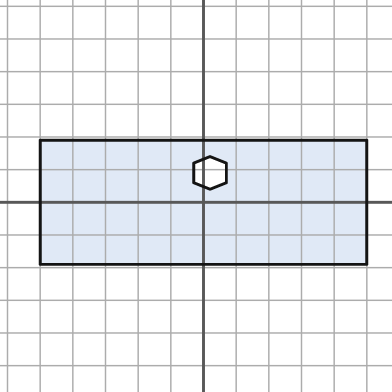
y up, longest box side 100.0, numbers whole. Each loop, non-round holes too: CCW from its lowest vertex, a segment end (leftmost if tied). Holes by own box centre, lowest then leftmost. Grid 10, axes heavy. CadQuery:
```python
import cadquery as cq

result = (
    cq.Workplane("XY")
    .moveTo(-50.0, -19.0)
    .lineTo(50.0, -19.0)
    .lineTo(50.0, 19.0)
    .lineTo(-50.0, 19.0)
    .close()
    .moveTo(2.0, 4.0)
    .lineTo(7.0, 6.0)
    .lineTo(7.0, 12.0)
    .lineTo(2.0, 14.0)
    .lineTo(-3.0, 12.0)
    .lineTo(-3.0, 6.0)
    .close()
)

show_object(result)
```